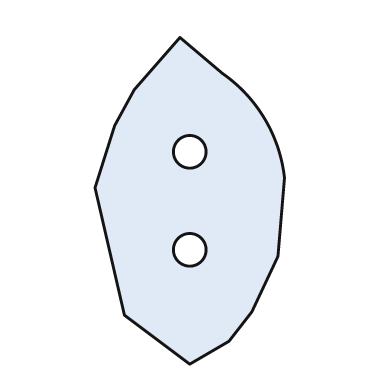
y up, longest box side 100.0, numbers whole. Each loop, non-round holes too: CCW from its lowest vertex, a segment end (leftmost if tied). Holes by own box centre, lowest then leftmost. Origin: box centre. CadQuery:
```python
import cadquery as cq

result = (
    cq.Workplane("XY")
    .moveTo(0.0, -50.0)
    .lineTo(12.0, -43.0)
    .lineTo(19.0, -34.0)
    .lineTo(27.0, -17.0)
    .lineTo(29.0, 7.0)
    .threePointArc((23.0, 25.0), (10.0, 39.0))
    .lineTo(-3.0, 50.0)
    .lineTo(-17.0, 34.0)
    .lineTo(-23.0, 23.0)
    .lineTo(-29.0, 4.0)
    .lineTo(-20.0, -35.0)
    .close()
    .moveTo(0.0, -15.0)
    .circle(5.0)
    .moveTo(0.0, 15.0)
    .circle(5.0)
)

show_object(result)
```